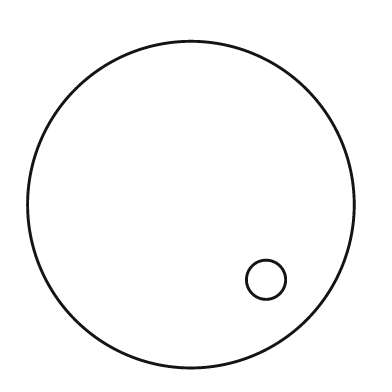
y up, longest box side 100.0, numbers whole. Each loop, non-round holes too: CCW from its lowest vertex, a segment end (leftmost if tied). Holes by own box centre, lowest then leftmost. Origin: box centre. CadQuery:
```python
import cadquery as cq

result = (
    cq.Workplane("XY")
    .moveTo(0.0, 0.0)
    .circle(50.0)
    .moveTo(23.0, -23.0)
    .circle(6.0)
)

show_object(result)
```